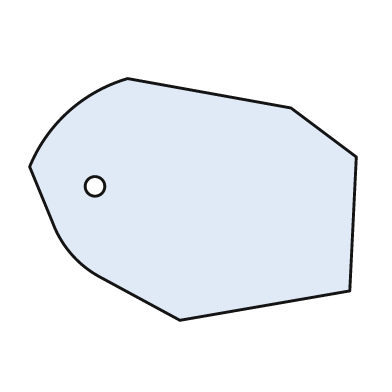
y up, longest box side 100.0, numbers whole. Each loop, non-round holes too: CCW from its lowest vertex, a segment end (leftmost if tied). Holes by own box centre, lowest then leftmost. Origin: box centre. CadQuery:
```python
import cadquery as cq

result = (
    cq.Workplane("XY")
    .moveTo(-4.0, -37.0)
    .lineTo(48.0, -28.0)
    .lineTo(50.0, 13.0)
    .lineTo(30.0, 28.0)
    .lineTo(-20.0, 37.0)
    .threePointArc((-38.0, 27.0), (-50.0, 10.0))
    .lineTo(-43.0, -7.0)
    .threePointArc((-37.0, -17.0), (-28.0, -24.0))
    .close()
    .moveTo(-30.0, 4.0)
    .circle(3.0)
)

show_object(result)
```